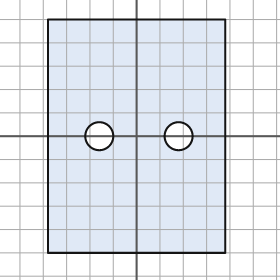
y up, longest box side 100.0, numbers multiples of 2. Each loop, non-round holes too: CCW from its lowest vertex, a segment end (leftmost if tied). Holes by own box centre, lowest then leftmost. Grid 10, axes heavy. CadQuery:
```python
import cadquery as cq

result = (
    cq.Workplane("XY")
    .moveTo(-38.0, -50.0)
    .lineTo(38.0, -50.0)
    .lineTo(38.0, 50.0)
    .lineTo(-38.0, 50.0)
    .close()
    .moveTo(-16.0, 0.0)
    .circle(6.0)
    .moveTo(18.0, 0.0)
    .circle(6.0)
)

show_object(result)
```